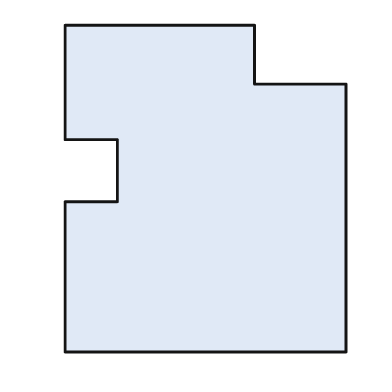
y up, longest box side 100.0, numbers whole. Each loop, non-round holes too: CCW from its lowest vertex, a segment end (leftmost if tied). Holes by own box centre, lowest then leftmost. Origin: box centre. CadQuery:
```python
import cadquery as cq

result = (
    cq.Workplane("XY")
    .moveTo(-43.0, -50.0)
    .lineTo(43.0, -50.0)
    .lineTo(43.0, 32.0)
    .lineTo(15.0, 32.0)
    .lineTo(15.0, 50.0)
    .lineTo(-43.0, 50.0)
    .lineTo(-43.0, 15.0)
    .lineTo(-27.0, 15.0)
    .lineTo(-27.0, -4.0)
    .lineTo(-43.0, -4.0)
    .close()
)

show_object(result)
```